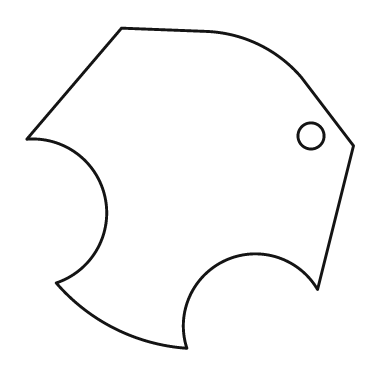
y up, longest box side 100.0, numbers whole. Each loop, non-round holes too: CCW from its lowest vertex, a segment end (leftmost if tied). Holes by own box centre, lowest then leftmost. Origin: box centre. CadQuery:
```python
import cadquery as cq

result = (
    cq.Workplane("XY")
    .moveTo(-1.0, -49.0)
    .threePointArc((11.0, -22.0), (39.0, -31.0))
    .lineTo(50.0, 13.0)
    .lineTo(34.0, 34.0)
    .threePointArc((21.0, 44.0), (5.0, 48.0))
    .lineTo(-21.0, 49.0)
    .lineTo(-50.0, 15.0)
    .threePointArc((-26.0, -3.0), (-41.0, -29.0))
    .threePointArc((-23.0, -43.0), (-1.0, -49.0))
    .close()
    .moveTo(37.0, 16.0)
    .circle(4.0)
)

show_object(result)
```